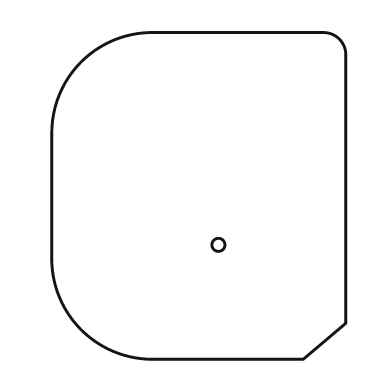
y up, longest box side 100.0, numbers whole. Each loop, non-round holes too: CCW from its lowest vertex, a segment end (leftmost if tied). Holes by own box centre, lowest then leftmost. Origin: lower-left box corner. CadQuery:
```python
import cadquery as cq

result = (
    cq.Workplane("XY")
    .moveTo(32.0, 0.0)
    .lineTo(77.0, 0.0)
    .lineTo(90.0, 11.0)
    .lineTo(90.0, 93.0)
    .threePointArc((88.0, 98.0), (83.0, 100.0))
    .lineTo(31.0, 100.0)
    .threePointArc((9.0, 91.0), (0.0, 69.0))
    .lineTo(0.0, 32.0)
    .threePointArc((9.0, 9.0), (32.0, 0.0))
    .close()
    .moveTo(51.0, 35.0)
    .circle(2.0)
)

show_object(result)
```